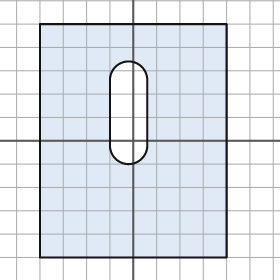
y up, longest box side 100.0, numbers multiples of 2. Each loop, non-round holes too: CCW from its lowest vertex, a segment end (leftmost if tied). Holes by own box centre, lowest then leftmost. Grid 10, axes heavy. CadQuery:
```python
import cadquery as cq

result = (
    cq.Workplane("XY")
    .moveTo(-40.0, -50.0)
    .lineTo(40.0, -50.0)
    .lineTo(40.0, 50.0)
    .lineTo(-40.0, 50.0)
    .close()
    .moveTo(-10.0, -2.0)
    .threePointArc((-2.0, -10.0), (6.0, -2.0))
    .lineTo(6.0, 26.0)
    .threePointArc((-2.0, 34.0), (-10.0, 26.0))
    .close()
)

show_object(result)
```